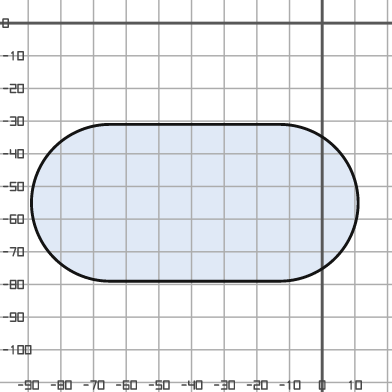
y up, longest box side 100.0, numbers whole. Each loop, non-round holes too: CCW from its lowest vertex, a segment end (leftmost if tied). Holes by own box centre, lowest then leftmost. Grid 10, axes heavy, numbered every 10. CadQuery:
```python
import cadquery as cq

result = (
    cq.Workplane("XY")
    .moveTo(-65.0, -79.0)
    .lineTo(-13.0, -79.0)
    .threePointArc((11.0, -55.0), (-13.0, -31.0))
    .lineTo(-65.0, -31.0)
    .threePointArc((-89.0, -55.0), (-65.0, -79.0))
    .close()
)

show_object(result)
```